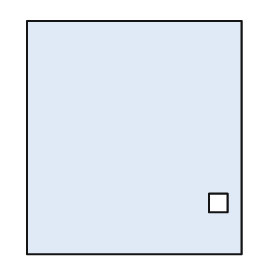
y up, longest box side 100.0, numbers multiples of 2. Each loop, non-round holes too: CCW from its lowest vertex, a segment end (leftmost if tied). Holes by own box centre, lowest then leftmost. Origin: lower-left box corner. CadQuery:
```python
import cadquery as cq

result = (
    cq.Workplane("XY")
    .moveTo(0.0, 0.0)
    .lineTo(92.0, 0.0)
    .lineTo(92.0, 100.0)
    .lineTo(0.0, 100.0)
    .close()
    .moveTo(78.0, 18.0)
    .lineTo(86.0, 18.0)
    .lineTo(86.0, 26.0)
    .lineTo(78.0, 26.0)
    .close()
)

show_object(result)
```